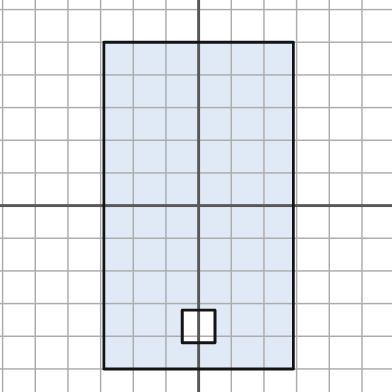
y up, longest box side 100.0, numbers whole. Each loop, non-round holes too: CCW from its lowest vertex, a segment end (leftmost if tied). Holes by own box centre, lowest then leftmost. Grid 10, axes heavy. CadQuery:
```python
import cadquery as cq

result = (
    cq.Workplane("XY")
    .moveTo(-29.0, -50.0)
    .lineTo(29.0, -50.0)
    .lineTo(29.0, 50.0)
    .lineTo(-29.0, 50.0)
    .close()
    .moveTo(-5.0, -42.0)
    .lineTo(5.0, -42.0)
    .lineTo(5.0, -32.0)
    .lineTo(-5.0, -32.0)
    .close()
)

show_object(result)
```